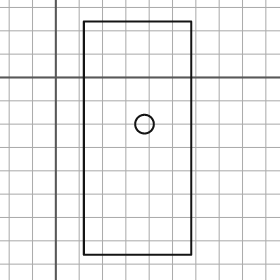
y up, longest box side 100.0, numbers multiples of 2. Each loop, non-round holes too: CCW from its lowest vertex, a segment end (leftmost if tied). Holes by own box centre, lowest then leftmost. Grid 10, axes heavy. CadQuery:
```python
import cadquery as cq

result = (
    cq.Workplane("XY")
    .moveTo(12.0, -76.0)
    .lineTo(58.0, -76.0)
    .lineTo(58.0, 24.0)
    .lineTo(12.0, 24.0)
    .close()
    .moveTo(38.0, -20.0)
    .circle(4.0)
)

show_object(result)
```